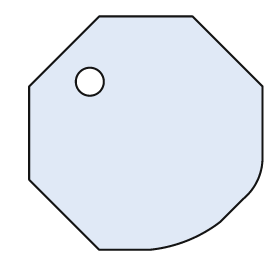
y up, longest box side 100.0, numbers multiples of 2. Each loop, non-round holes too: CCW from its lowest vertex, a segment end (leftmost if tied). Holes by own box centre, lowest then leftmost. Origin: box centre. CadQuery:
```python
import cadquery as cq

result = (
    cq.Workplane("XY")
    .moveTo(-20.0, -50.0)
    .lineTo(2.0, -50.0)
    .threePointArc((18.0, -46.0), (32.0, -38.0))
    .lineTo(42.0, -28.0)
    .threePointArc((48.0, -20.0), (50.0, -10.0))
    .lineTo(50.0, 20.0)
    .lineTo(20.0, 50.0)
    .lineTo(-20.0, 50.0)
    .lineTo(-50.0, 20.0)
    .lineTo(-50.0, -20.0)
    .close()
    .moveTo(-24.0, 22.0)
    .circle(6.0)
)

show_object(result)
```